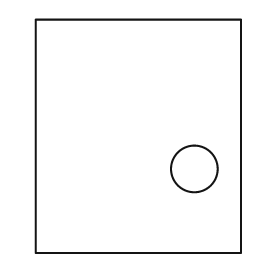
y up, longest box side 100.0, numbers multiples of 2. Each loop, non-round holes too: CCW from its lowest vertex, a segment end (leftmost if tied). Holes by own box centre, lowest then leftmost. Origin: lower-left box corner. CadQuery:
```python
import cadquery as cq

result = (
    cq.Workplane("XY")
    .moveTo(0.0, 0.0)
    .lineTo(88.0, 0.0)
    .lineTo(88.0, 100.0)
    .lineTo(0.0, 100.0)
    .close()
    .moveTo(68.0, 36.0)
    .circle(10.0)
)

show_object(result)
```